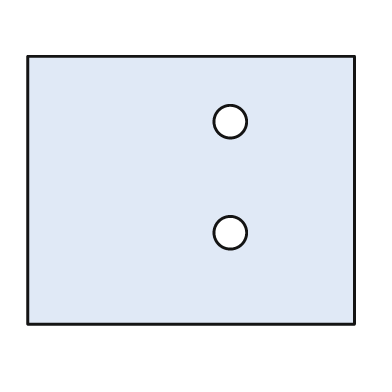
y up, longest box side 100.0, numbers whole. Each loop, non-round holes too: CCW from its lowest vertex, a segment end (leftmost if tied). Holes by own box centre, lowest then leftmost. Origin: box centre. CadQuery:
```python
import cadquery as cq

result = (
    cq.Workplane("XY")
    .moveTo(-50.0, -41.0)
    .lineTo(50.0, -41.0)
    .lineTo(50.0, 41.0)
    .lineTo(-50.0, 41.0)
    .close()
    .moveTo(12.0, -13.0)
    .circle(5.0)
    .moveTo(12.0, 21.0)
    .circle(5.0)
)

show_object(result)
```